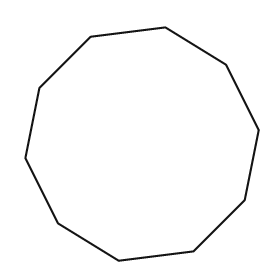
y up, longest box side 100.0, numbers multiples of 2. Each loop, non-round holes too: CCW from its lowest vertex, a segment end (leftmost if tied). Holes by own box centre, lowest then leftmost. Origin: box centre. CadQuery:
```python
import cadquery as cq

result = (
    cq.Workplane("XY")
    .moveTo(-10.0, -50.0)
    .lineTo(22.0, -46.0)
    .lineTo(44.0, -24.0)
    .lineTo(50.0, 6.0)
    .lineTo(36.0, 34.0)
    .lineTo(10.0, 50.0)
    .lineTo(-22.0, 46.0)
    .lineTo(-44.0, 24.0)
    .lineTo(-50.0, -6.0)
    .lineTo(-36.0, -34.0)
    .close()
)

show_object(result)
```